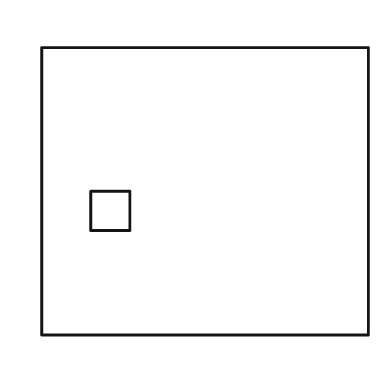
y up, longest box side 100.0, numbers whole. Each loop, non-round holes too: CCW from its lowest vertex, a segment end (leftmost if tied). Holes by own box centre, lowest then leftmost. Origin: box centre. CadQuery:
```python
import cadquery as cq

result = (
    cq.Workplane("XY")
    .moveTo(-50.0, -44.0)
    .lineTo(50.0, -44.0)
    .lineTo(50.0, 44.0)
    .lineTo(-50.0, 44.0)
    .close()
    .moveTo(-35.0, -12.0)
    .lineTo(-23.0, -12.0)
    .lineTo(-23.0, 0.0)
    .lineTo(-35.0, 0.0)
    .close()
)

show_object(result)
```